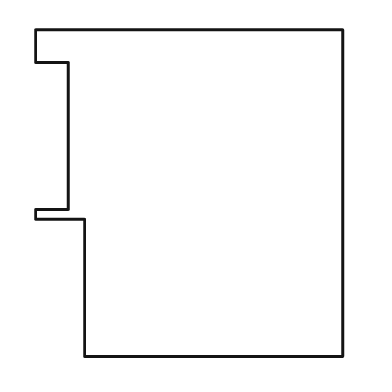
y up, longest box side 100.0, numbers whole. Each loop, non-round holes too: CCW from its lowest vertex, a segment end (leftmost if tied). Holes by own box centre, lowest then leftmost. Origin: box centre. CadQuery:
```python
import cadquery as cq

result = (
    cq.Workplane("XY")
    .moveTo(-32.0, -50.0)
    .lineTo(47.0, -50.0)
    .lineTo(47.0, 50.0)
    .lineTo(-47.0, 50.0)
    .lineTo(-47.0, 40.0)
    .lineTo(-37.0, 40.0)
    .lineTo(-37.0, -5.0)
    .lineTo(-47.0, -5.0)
    .lineTo(-47.0, -8.0)
    .lineTo(-32.0, -8.0)
    .close()
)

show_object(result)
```